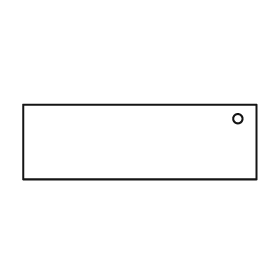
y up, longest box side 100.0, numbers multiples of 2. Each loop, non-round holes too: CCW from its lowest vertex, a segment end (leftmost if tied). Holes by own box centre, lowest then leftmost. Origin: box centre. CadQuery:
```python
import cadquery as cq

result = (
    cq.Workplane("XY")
    .moveTo(-50.0, -16.0)
    .lineTo(50.0, -16.0)
    .lineTo(50.0, 16.0)
    .lineTo(-50.0, 16.0)
    .close()
    .moveTo(42.0, 10.0)
    .circle(2.0)
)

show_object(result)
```